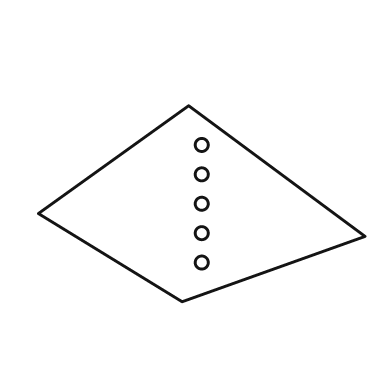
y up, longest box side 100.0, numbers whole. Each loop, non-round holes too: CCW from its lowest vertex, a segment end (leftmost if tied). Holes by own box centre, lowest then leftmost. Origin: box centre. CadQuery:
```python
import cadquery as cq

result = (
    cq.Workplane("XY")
    .moveTo(-6.0, -30.0)
    .lineTo(50.0, -10.0)
    .lineTo(-4.0, 30.0)
    .lineTo(-50.0, -3.0)
    .close()
    .moveTo(0.0, -18.0)
    .circle(2.0)
    .moveTo(0.0, -9.0)
    .circle(2.0)
    .moveTo(0.0, 0.0)
    .circle(2.0)
    .moveTo(0.0, 9.0)
    .circle(2.0)
    .moveTo(0.0, 18.0)
    .circle(2.0)
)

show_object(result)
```